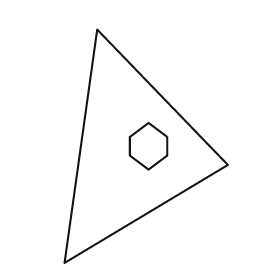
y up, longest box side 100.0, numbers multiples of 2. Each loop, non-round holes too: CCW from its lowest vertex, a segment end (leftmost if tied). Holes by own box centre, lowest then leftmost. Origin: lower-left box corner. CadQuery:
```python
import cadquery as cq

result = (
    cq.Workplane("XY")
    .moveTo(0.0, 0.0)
    .lineTo(70.0, 42.0)
    .lineTo(14.0, 100.0)
    .close()
    .moveTo(36.0, 40.0)
    .lineTo(44.0, 46.0)
    .lineTo(44.0, 54.0)
    .lineTo(36.0, 60.0)
    .lineTo(28.0, 54.0)
    .lineTo(28.0, 46.0)
    .close()
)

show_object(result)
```